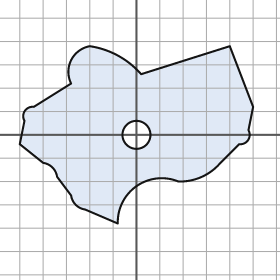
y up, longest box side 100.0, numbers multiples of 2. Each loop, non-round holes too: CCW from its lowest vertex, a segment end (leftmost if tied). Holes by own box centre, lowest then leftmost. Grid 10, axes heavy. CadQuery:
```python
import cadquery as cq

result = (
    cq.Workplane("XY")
    .moveTo(-8.0, -38.0)
    .threePointArc((0.0, -22.0), (18.0, -20.0))
    .threePointArc((28.0, -18.0), (36.0, -12.0))
    .lineTo(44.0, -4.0)
    .threePointArc((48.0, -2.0), (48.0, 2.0))
    .lineTo(50.0, 12.0)
    .lineTo(40.0, 38.0)
    .lineTo(2.0, 26.0)
    .threePointArc((-8.0, 34.0), (-20.0, 38.0))
    .threePointArc((-28.0, 32.0), (-28.0, 22.0))
    .lineTo(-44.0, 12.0)
    .threePointArc((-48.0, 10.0), (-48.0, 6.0))
    .lineTo(-50.0, -4.0)
    .lineTo(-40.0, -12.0)
    .threePointArc((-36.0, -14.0), (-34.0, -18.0))
    .lineTo(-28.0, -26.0)
    .threePointArc((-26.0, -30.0), (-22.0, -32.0))
    .close()
    .moveTo(0.0, 0.0)
    .circle(6.0)
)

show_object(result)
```